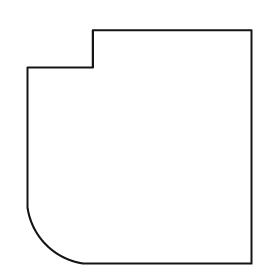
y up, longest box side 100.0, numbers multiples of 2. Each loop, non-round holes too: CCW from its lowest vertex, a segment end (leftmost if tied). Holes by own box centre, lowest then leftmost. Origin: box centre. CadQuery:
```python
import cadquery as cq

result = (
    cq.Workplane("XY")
    .moveTo(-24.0, -50.0)
    .lineTo(48.0, -50.0)
    .lineTo(48.0, 50.0)
    .lineTo(-20.0, 50.0)
    .lineTo(-20.0, 34.0)
    .lineTo(-48.0, 34.0)
    .lineTo(-48.0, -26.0)
    .threePointArc((-40.0, -42.0), (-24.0, -50.0))
    .close()
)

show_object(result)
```